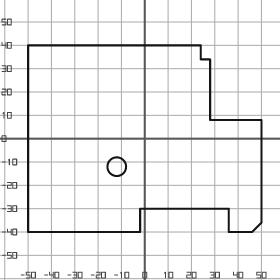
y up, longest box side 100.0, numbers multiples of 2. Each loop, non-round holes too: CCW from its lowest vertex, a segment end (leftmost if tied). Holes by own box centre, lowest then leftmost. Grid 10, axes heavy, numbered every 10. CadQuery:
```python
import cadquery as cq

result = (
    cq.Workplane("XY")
    .moveTo(-50.0, -40.0)
    .lineTo(-2.0, -40.0)
    .lineTo(-2.0, -30.0)
    .lineTo(36.0, -30.0)
    .lineTo(36.0, -40.0)
    .lineTo(46.0, -40.0)
    .lineTo(50.0, -36.0)
    .lineTo(50.0, 8.0)
    .lineTo(28.0, 8.0)
    .lineTo(28.0, 34.0)
    .lineTo(24.0, 34.0)
    .lineTo(24.0, 40.0)
    .lineTo(-50.0, 40.0)
    .close()
    .moveTo(-12.0, -12.0)
    .circle(4.0)
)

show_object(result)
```